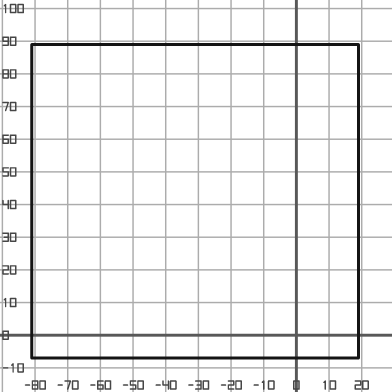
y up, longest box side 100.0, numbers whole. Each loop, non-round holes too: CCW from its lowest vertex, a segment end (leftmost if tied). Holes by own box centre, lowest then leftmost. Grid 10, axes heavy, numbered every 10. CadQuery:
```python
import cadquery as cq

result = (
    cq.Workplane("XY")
    .moveTo(-81.0, -7.0)
    .lineTo(19.0, -7.0)
    .lineTo(19.0, 89.0)
    .lineTo(-81.0, 89.0)
    .close()
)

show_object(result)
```